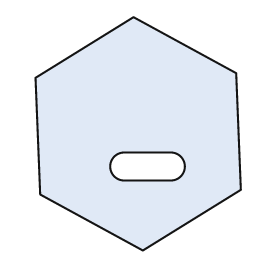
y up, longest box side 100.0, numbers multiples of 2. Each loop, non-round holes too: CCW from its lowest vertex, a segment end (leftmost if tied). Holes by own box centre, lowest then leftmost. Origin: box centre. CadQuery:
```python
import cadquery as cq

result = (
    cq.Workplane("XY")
    .moveTo(2.0, -50.0)
    .lineTo(44.0, -24.0)
    .lineTo(42.0, 26.0)
    .lineTo(-2.0, 50.0)
    .lineTo(-44.0, 24.0)
    .lineTo(-42.0, -26.0)
    .close()
    .moveTo(-6.0, -20.0)
    .lineTo(14.0, -20.0)
    .threePointArc((20.0, -14.0), (14.0, -8.0))
    .lineTo(-6.0, -8.0)
    .threePointArc((-12.0, -14.0), (-6.0, -20.0))
    .close()
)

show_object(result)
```